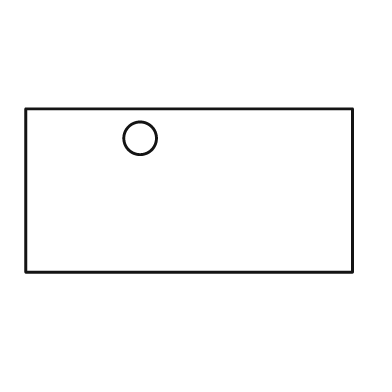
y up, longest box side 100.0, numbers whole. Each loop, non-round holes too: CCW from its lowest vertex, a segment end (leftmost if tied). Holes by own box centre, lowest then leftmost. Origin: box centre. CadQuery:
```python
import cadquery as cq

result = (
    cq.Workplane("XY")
    .moveTo(-50.0, -25.0)
    .lineTo(50.0, -25.0)
    .lineTo(50.0, 25.0)
    .lineTo(-50.0, 25.0)
    .close()
    .moveTo(-15.0, 16.0)
    .circle(5.0)
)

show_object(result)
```